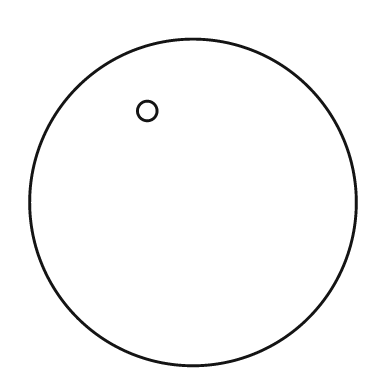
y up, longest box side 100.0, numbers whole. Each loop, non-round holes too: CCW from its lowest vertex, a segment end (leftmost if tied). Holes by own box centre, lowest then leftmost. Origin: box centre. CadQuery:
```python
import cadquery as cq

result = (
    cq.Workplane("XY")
    .moveTo(0.0, 0.0)
    .circle(50.0)
    .moveTo(-14.0, 28.0)
    .circle(3.0)
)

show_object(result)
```